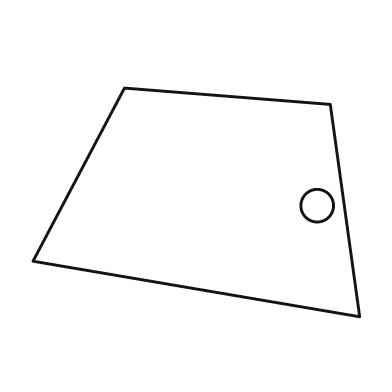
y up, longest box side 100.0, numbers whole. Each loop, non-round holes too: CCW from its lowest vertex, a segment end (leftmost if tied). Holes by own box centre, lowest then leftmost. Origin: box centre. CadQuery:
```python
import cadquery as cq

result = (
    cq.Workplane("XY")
    .moveTo(50.0, -35.0)
    .lineTo(41.0, 30.0)
    .lineTo(-22.0, 35.0)
    .lineTo(-50.0, -18.0)
    .close()
    .moveTo(37.0, -1.0)
    .circle(5.0)
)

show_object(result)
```